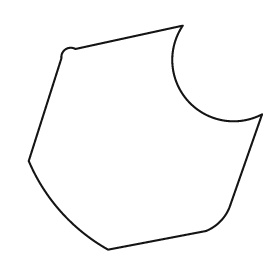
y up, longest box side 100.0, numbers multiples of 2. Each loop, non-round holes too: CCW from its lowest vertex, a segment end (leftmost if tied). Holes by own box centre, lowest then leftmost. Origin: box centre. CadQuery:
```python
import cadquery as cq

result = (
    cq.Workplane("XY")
    .moveTo(-16.0, -48.0)
    .lineTo(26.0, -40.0)
    .threePointArc((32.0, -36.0), (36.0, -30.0))
    .lineTo(50.0, 10.0)
    .threePointArc((18.0, 16.0), (16.0, 48.0))
    .lineTo(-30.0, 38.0)
    .threePointArc((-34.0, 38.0), (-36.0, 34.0))
    .lineTo(-50.0, -10.0)
    .threePointArc((-36.0, -32.0), (-16.0, -48.0))
    .close()
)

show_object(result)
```